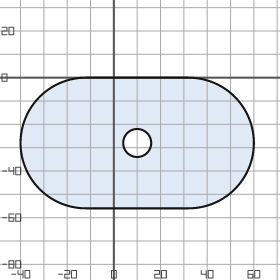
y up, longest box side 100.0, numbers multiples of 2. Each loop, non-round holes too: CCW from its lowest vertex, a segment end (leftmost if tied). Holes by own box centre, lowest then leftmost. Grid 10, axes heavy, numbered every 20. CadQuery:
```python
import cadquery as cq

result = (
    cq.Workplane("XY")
    .moveTo(-12.0, -56.0)
    .lineTo(32.0, -56.0)
    .threePointArc((60.0, -28.0), (32.0, 0.0))
    .lineTo(-12.0, 0.0)
    .threePointArc((-40.0, -28.0), (-12.0, -56.0))
    .close()
    .moveTo(10.0, -28.0)
    .circle(6.0)
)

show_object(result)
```